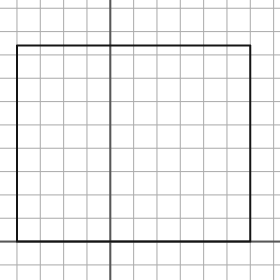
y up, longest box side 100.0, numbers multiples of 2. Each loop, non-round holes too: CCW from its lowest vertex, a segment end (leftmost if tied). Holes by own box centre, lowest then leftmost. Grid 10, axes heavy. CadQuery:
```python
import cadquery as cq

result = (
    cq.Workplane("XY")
    .moveTo(-40.0, 0.0)
    .lineTo(60.0, 0.0)
    .lineTo(60.0, 84.0)
    .lineTo(-40.0, 84.0)
    .close()
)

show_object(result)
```